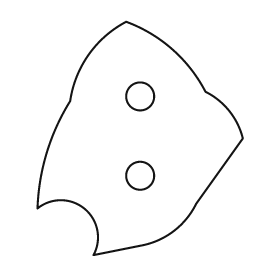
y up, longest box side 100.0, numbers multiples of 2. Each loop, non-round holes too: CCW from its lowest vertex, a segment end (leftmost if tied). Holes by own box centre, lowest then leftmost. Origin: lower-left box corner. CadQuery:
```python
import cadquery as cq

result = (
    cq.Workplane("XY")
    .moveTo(24.0, 0.0)
    .lineTo(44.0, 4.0)
    .threePointArc((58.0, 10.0), (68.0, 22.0))
    .lineTo(88.0, 50.0)
    .threePointArc((82.0, 62.0), (72.0, 70.0))
    .threePointArc((58.0, 88.0), (38.0, 100.0))
    .threePointArc((22.0, 86.0), (14.0, 66.0))
    .threePointArc((4.0, 44.0), (0.0, 20.0))
    .threePointArc((20.0, 20.0), (24.0, 0.0))
    .close()
    .moveTo(44.0, 34.0)
    .circle(6.0)
    .moveTo(44.0, 68.0)
    .circle(6.0)
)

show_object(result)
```